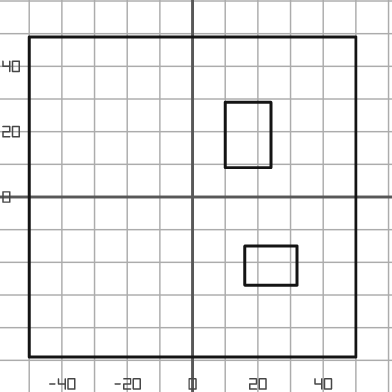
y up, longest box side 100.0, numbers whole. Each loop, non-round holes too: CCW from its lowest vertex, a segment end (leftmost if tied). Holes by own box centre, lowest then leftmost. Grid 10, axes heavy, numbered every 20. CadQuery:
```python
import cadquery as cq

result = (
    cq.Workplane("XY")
    .moveTo(-50.0, -49.0)
    .lineTo(50.0, -49.0)
    .lineTo(50.0, 49.0)
    .lineTo(-50.0, 49.0)
    .close()
    .moveTo(16.0, -27.0)
    .lineTo(32.0, -27.0)
    .lineTo(32.0, -15.0)
    .lineTo(16.0, -15.0)
    .close()
    .moveTo(10.0, 9.0)
    .lineTo(24.0, 9.0)
    .lineTo(24.0, 29.0)
    .lineTo(10.0, 29.0)
    .close()
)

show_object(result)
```